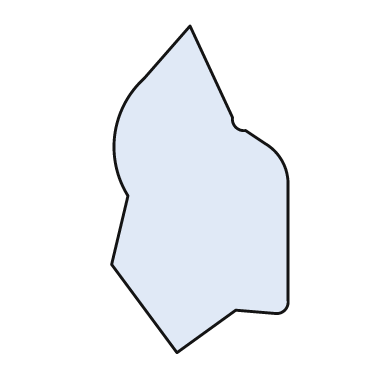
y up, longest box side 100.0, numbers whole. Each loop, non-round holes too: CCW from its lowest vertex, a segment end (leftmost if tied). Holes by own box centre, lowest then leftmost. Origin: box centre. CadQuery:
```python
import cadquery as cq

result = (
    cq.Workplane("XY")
    .moveTo(-7.0, -50.0)
    .lineTo(11.0, -37.0)
    .lineTo(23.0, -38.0)
    .threePointArc((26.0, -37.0), (27.0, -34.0))
    .lineTo(27.0, 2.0)
    .threePointArc((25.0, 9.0), (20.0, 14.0))
    .lineTo(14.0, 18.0)
    .threePointArc((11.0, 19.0), (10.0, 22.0))
    .lineTo(-3.0, 50.0)
    .lineTo(-17.0, 34.0)
    .threePointArc((-26.0, 17.0), (-22.0, -2.0))
    .lineTo(-27.0, -23.0)
    .close()
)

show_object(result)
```